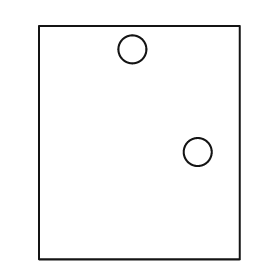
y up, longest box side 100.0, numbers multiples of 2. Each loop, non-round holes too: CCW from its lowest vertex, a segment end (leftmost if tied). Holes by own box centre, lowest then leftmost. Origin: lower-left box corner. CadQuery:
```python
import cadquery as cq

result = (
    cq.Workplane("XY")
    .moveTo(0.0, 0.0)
    .lineTo(86.0, 0.0)
    .lineTo(86.0, 100.0)
    .lineTo(0.0, 100.0)
    .close()
    .moveTo(68.0, 46.0)
    .circle(6.0)
    .moveTo(40.0, 90.0)
    .circle(6.0)
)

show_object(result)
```